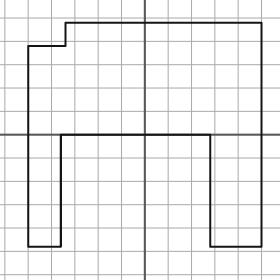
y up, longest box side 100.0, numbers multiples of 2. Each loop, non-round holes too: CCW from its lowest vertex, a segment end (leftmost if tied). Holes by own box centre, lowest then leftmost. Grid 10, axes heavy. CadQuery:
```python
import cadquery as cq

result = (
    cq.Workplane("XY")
    .moveTo(-50.0, -48.0)
    .lineTo(-36.0, -48.0)
    .lineTo(-36.0, 0.0)
    .lineTo(28.0, 0.0)
    .lineTo(28.0, -48.0)
    .lineTo(50.0, -48.0)
    .lineTo(50.0, 48.0)
    .lineTo(-34.0, 48.0)
    .lineTo(-34.0, 38.0)
    .lineTo(-50.0, 38.0)
    .close()
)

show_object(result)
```